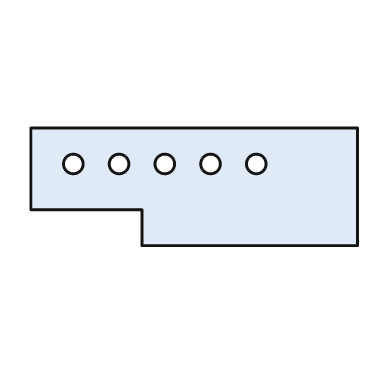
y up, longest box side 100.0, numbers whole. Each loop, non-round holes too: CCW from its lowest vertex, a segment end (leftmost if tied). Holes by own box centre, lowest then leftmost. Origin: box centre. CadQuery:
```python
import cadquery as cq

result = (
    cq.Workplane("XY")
    .moveTo(-16.0, -18.0)
    .lineTo(50.0, -18.0)
    .lineTo(50.0, 18.0)
    .lineTo(-50.0, 18.0)
    .lineTo(-50.0, -7.0)
    .lineTo(-16.0, -7.0)
    .close()
    .moveTo(-37.0, 7.0)
    .circle(3.0)
    .moveTo(-23.0, 7.0)
    .circle(3.0)
    .moveTo(-9.0, 7.0)
    .circle(3.0)
    .moveTo(5.0, 7.0)
    .circle(3.0)
    .moveTo(19.0, 7.0)
    .circle(3.0)
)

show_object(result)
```